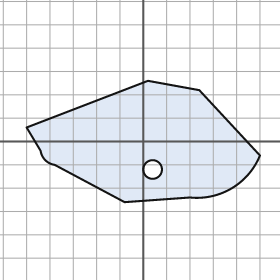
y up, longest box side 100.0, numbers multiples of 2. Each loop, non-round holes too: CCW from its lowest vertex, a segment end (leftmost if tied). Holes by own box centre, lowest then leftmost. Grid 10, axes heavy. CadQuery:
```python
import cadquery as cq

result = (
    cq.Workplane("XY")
    .moveTo(-8.0, -26.0)
    .lineTo(20.0, -24.0)
    .threePointArc((38.0, -20.0), (50.0, -6.0))
    .lineTo(24.0, 22.0)
    .lineTo(2.0, 26.0)
    .lineTo(-50.0, 6.0)
    .lineTo(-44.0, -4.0)
    .threePointArc((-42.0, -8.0), (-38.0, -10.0))
    .close()
    .moveTo(4.0, -12.0)
    .circle(4.0)
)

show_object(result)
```